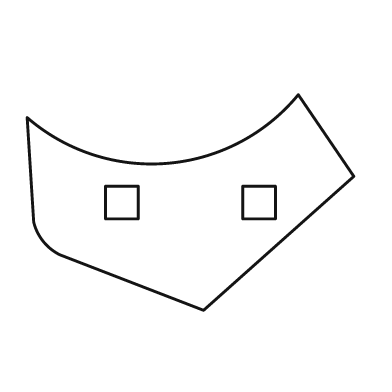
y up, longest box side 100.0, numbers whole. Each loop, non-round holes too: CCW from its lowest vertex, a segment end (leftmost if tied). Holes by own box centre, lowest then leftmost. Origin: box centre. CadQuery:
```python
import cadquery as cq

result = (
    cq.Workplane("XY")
    .moveTo(4.0, -33.0)
    .lineTo(50.0, 8.0)
    .lineTo(33.0, 33.0)
    .threePointArc((-7.0, 12.0), (-50.0, 26.0))
    .lineTo(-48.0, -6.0)
    .threePointArc((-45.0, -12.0), (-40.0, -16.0))
    .close()
    .moveTo(-26.0, -5.0)
    .lineTo(-16.0, -5.0)
    .lineTo(-16.0, 5.0)
    .lineTo(-26.0, 5.0)
    .close()
    .moveTo(16.0, -5.0)
    .lineTo(26.0, -5.0)
    .lineTo(26.0, 5.0)
    .lineTo(16.0, 5.0)
    .close()
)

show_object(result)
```